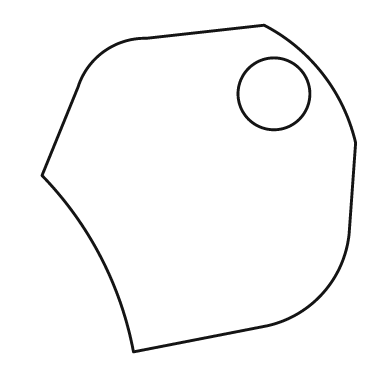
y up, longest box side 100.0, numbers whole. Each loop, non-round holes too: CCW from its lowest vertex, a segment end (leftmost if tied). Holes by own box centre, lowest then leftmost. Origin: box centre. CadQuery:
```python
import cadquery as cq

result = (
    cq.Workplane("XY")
    .moveTo(-20.0, -50.0)
    .lineTo(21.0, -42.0)
    .threePointArc((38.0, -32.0), (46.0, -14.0))
    .lineTo(48.0, 14.0)
    .threePointArc((38.0, 35.0), (20.0, 50.0))
    .lineTo(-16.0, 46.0)
    .threePointArc((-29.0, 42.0), (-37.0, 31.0))
    .lineTo(-48.0, 4.0)
    .threePointArc((-30.0, -21.0), (-20.0, -50.0))
    .close()
    .moveTo(23.0, 29.0)
    .circle(11.0)
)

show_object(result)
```